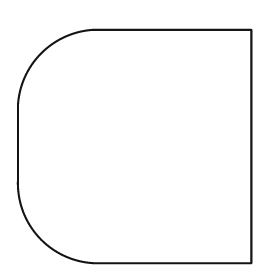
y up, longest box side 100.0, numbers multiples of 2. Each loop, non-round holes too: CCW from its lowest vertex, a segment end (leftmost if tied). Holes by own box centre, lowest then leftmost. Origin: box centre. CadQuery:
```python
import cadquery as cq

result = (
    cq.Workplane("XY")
    .moveTo(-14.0, -50.0)
    .lineTo(50.0, -50.0)
    .lineTo(50.0, 50.0)
    .lineTo(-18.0, 50.0)
    .threePointArc((-40.0, 40.0), (-50.0, 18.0))
    .lineTo(-50.0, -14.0)
    .threePointArc((-40.0, -40.0), (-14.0, -50.0))
    .close()
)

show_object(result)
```